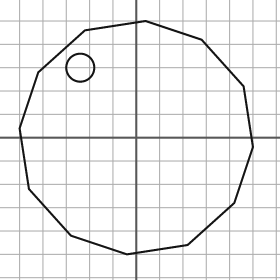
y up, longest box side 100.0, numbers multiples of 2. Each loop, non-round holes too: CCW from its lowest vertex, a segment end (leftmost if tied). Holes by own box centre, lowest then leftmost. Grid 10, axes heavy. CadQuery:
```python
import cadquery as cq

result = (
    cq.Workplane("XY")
    .moveTo(-4.0, -50.0)
    .lineTo(22.0, -46.0)
    .lineTo(42.0, -28.0)
    .lineTo(50.0, -4.0)
    .lineTo(46.0, 22.0)
    .lineTo(28.0, 42.0)
    .lineTo(4.0, 50.0)
    .lineTo(-22.0, 46.0)
    .lineTo(-42.0, 28.0)
    .lineTo(-50.0, 4.0)
    .lineTo(-46.0, -22.0)
    .lineTo(-28.0, -42.0)
    .close()
    .moveTo(-24.0, 30.0)
    .circle(6.0)
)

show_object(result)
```